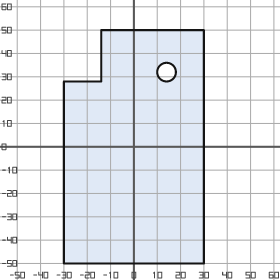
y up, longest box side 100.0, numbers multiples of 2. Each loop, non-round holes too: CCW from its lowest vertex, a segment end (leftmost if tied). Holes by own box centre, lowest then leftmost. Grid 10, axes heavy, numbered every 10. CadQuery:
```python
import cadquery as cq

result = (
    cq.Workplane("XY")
    .moveTo(-30.0, -50.0)
    .lineTo(30.0, -50.0)
    .lineTo(30.0, 50.0)
    .lineTo(-14.0, 50.0)
    .lineTo(-14.0, 28.0)
    .lineTo(-30.0, 28.0)
    .close()
    .moveTo(14.0, 32.0)
    .circle(4.0)
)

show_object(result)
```